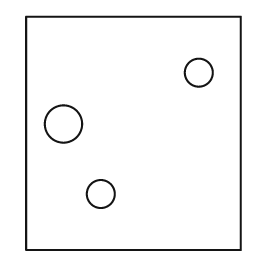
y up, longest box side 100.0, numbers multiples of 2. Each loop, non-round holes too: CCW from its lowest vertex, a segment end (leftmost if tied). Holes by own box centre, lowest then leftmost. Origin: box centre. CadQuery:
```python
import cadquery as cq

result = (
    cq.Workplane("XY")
    .moveTo(-46.0, -50.0)
    .lineTo(46.0, -50.0)
    .lineTo(46.0, 50.0)
    .lineTo(-46.0, 50.0)
    .close()
    .moveTo(-14.0, -26.0)
    .circle(6.0)
    .moveTo(-30.0, 4.0)
    .circle(8.0)
    .moveTo(28.0, 26.0)
    .circle(6.0)
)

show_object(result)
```